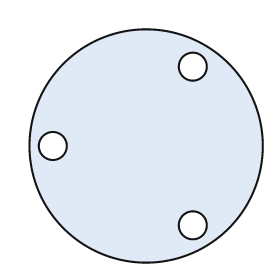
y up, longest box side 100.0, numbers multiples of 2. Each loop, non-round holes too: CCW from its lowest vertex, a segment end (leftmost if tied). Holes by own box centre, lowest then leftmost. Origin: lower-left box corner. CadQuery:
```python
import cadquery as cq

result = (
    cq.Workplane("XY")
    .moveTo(50.0, 50.0)
    .circle(50.0)
    .moveTo(70.0, 16.0)
    .circle(6.0)
    .moveTo(10.0, 50.0)
    .circle(6.0)
    .moveTo(70.0, 84.0)
    .circle(6.0)
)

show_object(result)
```